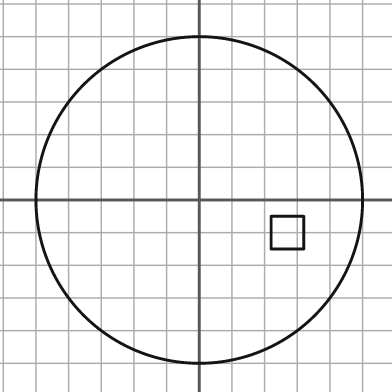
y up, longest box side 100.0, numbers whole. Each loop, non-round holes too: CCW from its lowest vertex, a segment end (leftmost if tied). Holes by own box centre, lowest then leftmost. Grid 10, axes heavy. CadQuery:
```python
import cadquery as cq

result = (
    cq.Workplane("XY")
    .moveTo(0.0, 0.0)
    .circle(50.0)
    .moveTo(22.0, -15.0)
    .lineTo(32.0, -15.0)
    .lineTo(32.0, -5.0)
    .lineTo(22.0, -5.0)
    .close()
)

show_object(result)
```